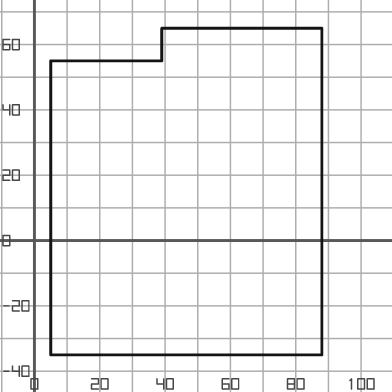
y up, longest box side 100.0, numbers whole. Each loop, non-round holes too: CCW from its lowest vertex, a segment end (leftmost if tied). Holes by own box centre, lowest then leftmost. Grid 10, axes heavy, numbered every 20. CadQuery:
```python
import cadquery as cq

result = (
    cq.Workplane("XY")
    .moveTo(5.0, -35.0)
    .lineTo(88.0, -35.0)
    .lineTo(88.0, 65.0)
    .lineTo(39.0, 65.0)
    .lineTo(39.0, 55.0)
    .lineTo(5.0, 55.0)
    .close()
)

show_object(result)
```